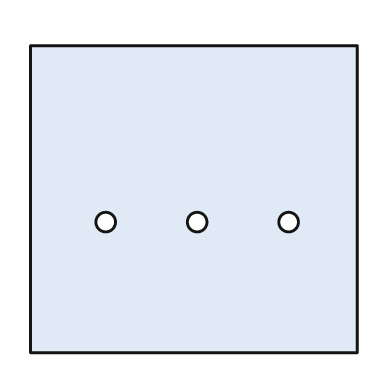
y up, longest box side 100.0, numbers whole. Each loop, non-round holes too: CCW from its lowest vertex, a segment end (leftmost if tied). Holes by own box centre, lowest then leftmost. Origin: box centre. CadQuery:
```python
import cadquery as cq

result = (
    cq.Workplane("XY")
    .moveTo(-50.0, -47.0)
    .lineTo(50.0, -47.0)
    .lineTo(50.0, 47.0)
    .lineTo(-50.0, 47.0)
    .close()
    .moveTo(-27.0, -7.0)
    .circle(3.0)
    .moveTo(1.0, -7.0)
    .circle(3.0)
    .moveTo(29.0, -7.0)
    .circle(3.0)
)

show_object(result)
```